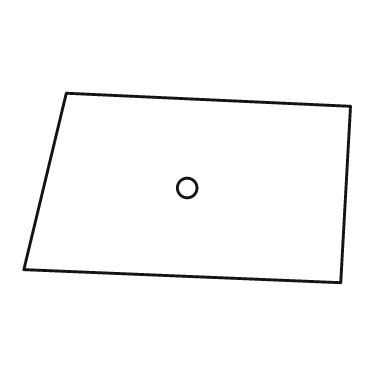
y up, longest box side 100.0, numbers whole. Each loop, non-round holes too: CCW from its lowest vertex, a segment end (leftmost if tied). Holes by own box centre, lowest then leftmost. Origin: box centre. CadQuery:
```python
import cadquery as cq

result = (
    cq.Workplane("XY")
    .moveTo(47.0, -29.0)
    .lineTo(50.0, 25.0)
    .lineTo(-37.0, 29.0)
    .lineTo(-50.0, -25.0)
    .close()
    .moveTo(0.0, 0.0)
    .circle(3.0)
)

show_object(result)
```